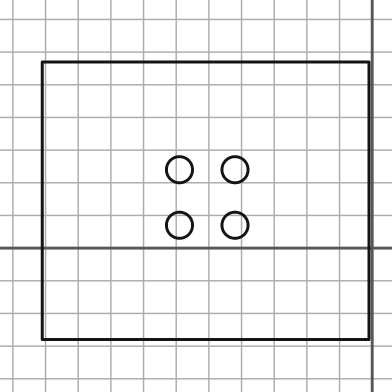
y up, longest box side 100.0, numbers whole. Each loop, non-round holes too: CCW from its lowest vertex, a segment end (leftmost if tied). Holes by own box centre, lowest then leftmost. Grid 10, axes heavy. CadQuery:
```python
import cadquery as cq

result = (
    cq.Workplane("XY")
    .moveTo(-101.0, -28.0)
    .lineTo(-1.0, -28.0)
    .lineTo(-1.0, 57.0)
    .lineTo(-101.0, 57.0)
    .close()
    .moveTo(-59.0, 7.0)
    .circle(4.0)
    .moveTo(-42.0, 7.0)
    .circle(4.0)
    .moveTo(-59.0, 24.0)
    .circle(4.0)
    .moveTo(-42.0, 24.0)
    .circle(4.0)
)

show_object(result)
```